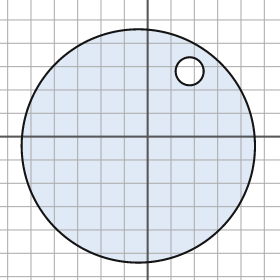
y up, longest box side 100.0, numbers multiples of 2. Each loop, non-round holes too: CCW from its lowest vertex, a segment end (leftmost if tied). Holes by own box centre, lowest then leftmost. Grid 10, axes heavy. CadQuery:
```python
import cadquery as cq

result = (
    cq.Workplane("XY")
    .moveTo(-4.0, -4.0)
    .circle(50.0)
    .moveTo(18.0, 28.0)
    .circle(6.0)
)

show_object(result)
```